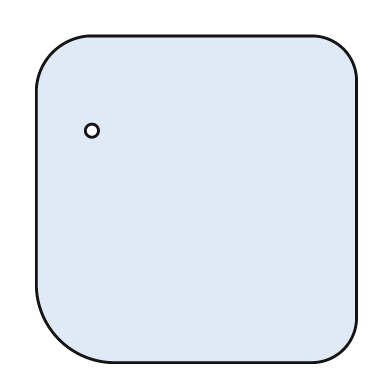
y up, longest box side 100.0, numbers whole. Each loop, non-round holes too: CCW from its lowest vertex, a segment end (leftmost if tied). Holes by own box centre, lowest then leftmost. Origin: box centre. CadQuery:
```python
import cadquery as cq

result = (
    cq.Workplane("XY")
    .moveTo(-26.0, -50.0)
    .lineTo(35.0, -50.0)
    .threePointArc((45.0, -46.0), (49.0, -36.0))
    .lineTo(49.0, 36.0)
    .threePointArc((45.0, 46.0), (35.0, 50.0))
    .lineTo(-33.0, 50.0)
    .threePointArc((-44.0, 45.0), (-49.0, 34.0))
    .lineTo(-49.0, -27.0)
    .threePointArc((-42.0, -43.0), (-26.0, -50.0))
    .close()
    .moveTo(-32.0, 21.0)
    .circle(2.0)
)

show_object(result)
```